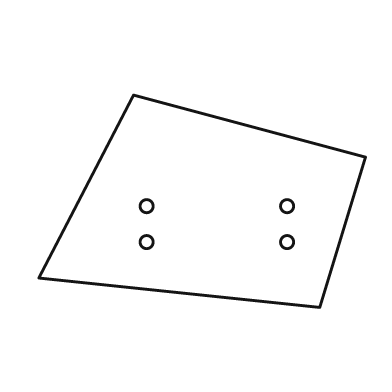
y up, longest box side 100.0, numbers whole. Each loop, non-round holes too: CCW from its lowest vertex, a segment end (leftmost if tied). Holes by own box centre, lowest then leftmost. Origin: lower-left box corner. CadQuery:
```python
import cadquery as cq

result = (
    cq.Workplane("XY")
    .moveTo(86.0, 0.0)
    .lineTo(100.0, 46.0)
    .lineTo(29.0, 65.0)
    .lineTo(0.0, 9.0)
    .close()
    .moveTo(33.0, 20.0)
    .circle(2.0)
    .moveTo(76.0, 20.0)
    .circle(2.0)
    .moveTo(33.0, 31.0)
    .circle(2.0)
    .moveTo(76.0, 31.0)
    .circle(2.0)
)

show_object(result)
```